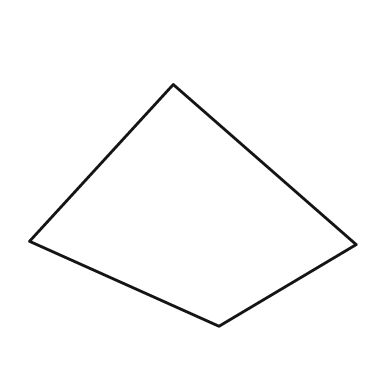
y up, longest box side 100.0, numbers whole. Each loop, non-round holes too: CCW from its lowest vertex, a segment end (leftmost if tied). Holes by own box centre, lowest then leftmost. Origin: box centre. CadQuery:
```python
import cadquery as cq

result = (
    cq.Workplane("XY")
    .moveTo(8.0, -37.0)
    .lineTo(50.0, -12.0)
    .lineTo(-6.0, 37.0)
    .lineTo(-50.0, -11.0)
    .close()
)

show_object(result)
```